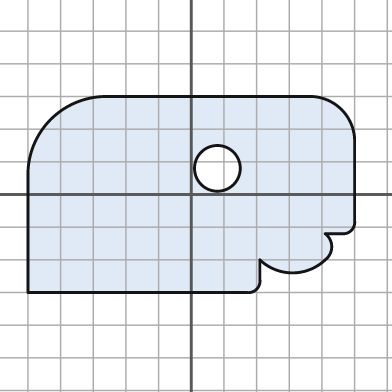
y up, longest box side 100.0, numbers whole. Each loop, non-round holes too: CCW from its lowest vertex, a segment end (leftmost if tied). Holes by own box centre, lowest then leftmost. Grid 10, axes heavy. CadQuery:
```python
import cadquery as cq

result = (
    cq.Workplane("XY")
    .moveTo(-50.0, -30.0)
    .lineTo(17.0, -30.0)
    .threePointArc((20.0, -29.0), (21.0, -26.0))
    .lineTo(21.0, -20.0)
    .threePointArc((31.0, -24.0), (41.0, -20.0))
    .threePointArc((43.0, -16.0), (41.0, -12.0))
    .lineTo(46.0, -12.0)
    .threePointArc((49.0, -11.0), (50.0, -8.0))
    .lineTo(50.0, 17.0)
    .threePointArc((46.0, 26.0), (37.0, 30.0))
    .lineTo(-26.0, 30.0)
    .threePointArc((-43.0, 23.0), (-50.0, 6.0))
    .close()
    .moveTo(8.0, 8.0)
    .circle(7.0)
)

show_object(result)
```